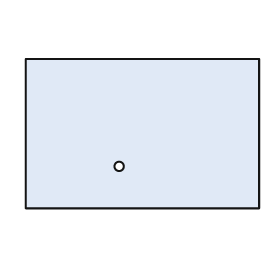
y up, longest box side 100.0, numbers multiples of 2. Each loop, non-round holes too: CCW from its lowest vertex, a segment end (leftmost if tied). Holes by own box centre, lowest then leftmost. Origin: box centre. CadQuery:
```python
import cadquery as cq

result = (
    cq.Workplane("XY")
    .moveTo(-50.0, -32.0)
    .lineTo(50.0, -32.0)
    .lineTo(50.0, 32.0)
    .lineTo(-50.0, 32.0)
    .close()
    .moveTo(-10.0, -14.0)
    .circle(2.0)
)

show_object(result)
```